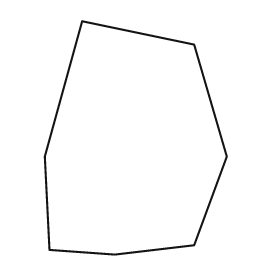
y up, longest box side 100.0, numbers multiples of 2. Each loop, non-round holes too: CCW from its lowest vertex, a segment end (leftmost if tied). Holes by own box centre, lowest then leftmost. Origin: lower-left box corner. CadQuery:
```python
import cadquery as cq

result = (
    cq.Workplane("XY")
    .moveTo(30.0, 0.0)
    .lineTo(64.0, 4.0)
    .lineTo(78.0, 42.0)
    .lineTo(64.0, 90.0)
    .lineTo(16.0, 100.0)
    .lineTo(0.0, 42.0)
    .lineTo(2.0, 2.0)
    .close()
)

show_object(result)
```